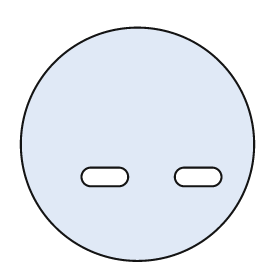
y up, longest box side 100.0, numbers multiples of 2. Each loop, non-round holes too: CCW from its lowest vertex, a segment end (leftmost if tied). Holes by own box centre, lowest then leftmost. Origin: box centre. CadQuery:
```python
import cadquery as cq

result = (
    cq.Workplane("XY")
    .moveTo(0.0, 0.0)
    .circle(50.0)
    .moveTo(-20.0, -18.0)
    .lineTo(-8.0, -18.0)
    .threePointArc((-4.0, -14.0), (-8.0, -10.0))
    .lineTo(-20.0, -10.0)
    .threePointArc((-24.0, -14.0), (-20.0, -18.0))
    .close()
    .moveTo(20.0, -18.0)
    .lineTo(32.0, -18.0)
    .threePointArc((36.0, -14.0), (32.0, -10.0))
    .lineTo(20.0, -10.0)
    .threePointArc((16.0, -14.0), (20.0, -18.0))
    .close()
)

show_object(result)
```